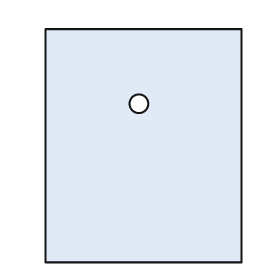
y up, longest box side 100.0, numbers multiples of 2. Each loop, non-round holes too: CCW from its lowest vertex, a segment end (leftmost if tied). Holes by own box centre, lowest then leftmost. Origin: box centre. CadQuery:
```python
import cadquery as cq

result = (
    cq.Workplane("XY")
    .moveTo(-42.0, -50.0)
    .lineTo(42.0, -50.0)
    .lineTo(42.0, 50.0)
    .lineTo(-42.0, 50.0)
    .close()
    .moveTo(-2.0, 18.0)
    .circle(4.0)
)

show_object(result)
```